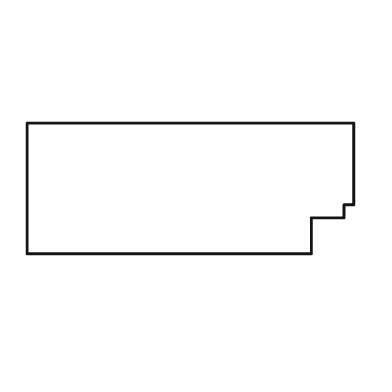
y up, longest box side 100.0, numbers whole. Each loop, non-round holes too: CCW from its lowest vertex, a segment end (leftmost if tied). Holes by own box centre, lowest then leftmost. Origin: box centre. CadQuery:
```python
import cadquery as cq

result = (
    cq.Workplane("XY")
    .moveTo(-50.0, -20.0)
    .lineTo(37.0, -20.0)
    .lineTo(37.0, -9.0)
    .lineTo(47.0, -9.0)
    .lineTo(47.0, -5.0)
    .lineTo(50.0, -5.0)
    .lineTo(50.0, 20.0)
    .lineTo(-50.0, 20.0)
    .close()
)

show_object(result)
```